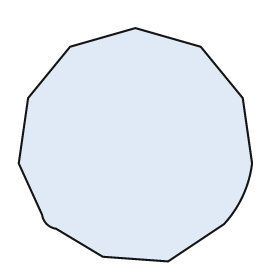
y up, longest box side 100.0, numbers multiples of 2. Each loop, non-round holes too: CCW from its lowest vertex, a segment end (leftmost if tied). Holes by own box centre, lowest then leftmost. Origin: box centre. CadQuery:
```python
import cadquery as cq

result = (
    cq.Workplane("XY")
    .moveTo(14.0, -50.0)
    .lineTo(38.0, -34.0)
    .threePointArc((46.0, -22.0), (50.0, -8.0))
    .lineTo(46.0, 20.0)
    .lineTo(28.0, 42.0)
    .lineTo(0.0, 50.0)
    .lineTo(-28.0, 42.0)
    .lineTo(-46.0, 20.0)
    .lineTo(-50.0, -8.0)
    .lineTo(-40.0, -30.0)
    .threePointArc((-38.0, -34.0), (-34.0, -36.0))
    .lineTo(-14.0, -48.0)
    .close()
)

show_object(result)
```